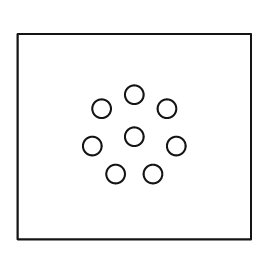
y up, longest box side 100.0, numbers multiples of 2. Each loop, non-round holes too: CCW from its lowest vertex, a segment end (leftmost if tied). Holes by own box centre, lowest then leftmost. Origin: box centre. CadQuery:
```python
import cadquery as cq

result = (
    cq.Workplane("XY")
    .moveTo(-50.0, -44.0)
    .lineTo(50.0, -44.0)
    .lineTo(50.0, 44.0)
    .lineTo(-50.0, 44.0)
    .close()
    .moveTo(-8.0, -16.0)
    .circle(4.0)
    .moveTo(8.0, -16.0)
    .circle(4.0)
    .moveTo(-18.0, -4.0)
    .circle(4.0)
    .moveTo(18.0, -4.0)
    .circle(4.0)
    .moveTo(0.0, 0.0)
    .circle(4.0)
    .moveTo(-14.0, 12.0)
    .circle(4.0)
    .moveTo(14.0, 12.0)
    .circle(4.0)
    .moveTo(0.0, 18.0)
    .circle(4.0)
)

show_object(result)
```